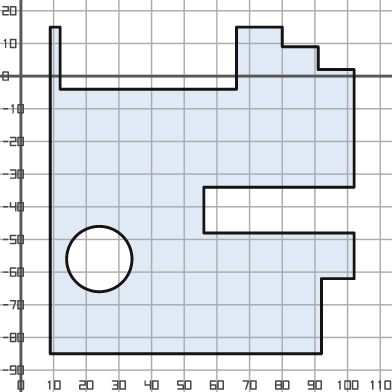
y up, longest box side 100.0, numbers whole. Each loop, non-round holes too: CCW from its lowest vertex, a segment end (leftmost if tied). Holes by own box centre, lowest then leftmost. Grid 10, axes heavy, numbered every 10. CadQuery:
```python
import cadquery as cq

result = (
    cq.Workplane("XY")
    .moveTo(9.0, -85.0)
    .lineTo(92.0, -85.0)
    .lineTo(92.0, -62.0)
    .lineTo(102.0, -62.0)
    .lineTo(102.0, -48.0)
    .lineTo(56.0, -48.0)
    .lineTo(56.0, -34.0)
    .lineTo(102.0, -34.0)
    .lineTo(102.0, 2.0)
    .lineTo(91.0, 2.0)
    .lineTo(91.0, 9.0)
    .lineTo(80.0, 9.0)
    .lineTo(80.0, 15.0)
    .lineTo(66.0, 15.0)
    .lineTo(66.0, -4.0)
    .lineTo(12.0, -4.0)
    .lineTo(12.0, 15.0)
    .lineTo(9.0, 15.0)
    .close()
    .moveTo(24.0, -56.0)
    .circle(10.0)
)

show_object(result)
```